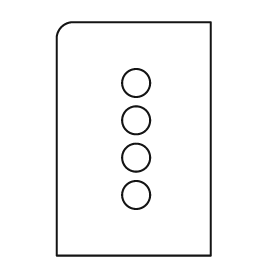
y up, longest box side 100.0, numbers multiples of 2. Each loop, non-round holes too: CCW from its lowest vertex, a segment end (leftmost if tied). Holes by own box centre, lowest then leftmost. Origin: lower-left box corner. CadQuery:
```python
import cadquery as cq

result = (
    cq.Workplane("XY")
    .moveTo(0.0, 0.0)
    .lineTo(66.0, 0.0)
    .lineTo(66.0, 100.0)
    .lineTo(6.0, 100.0)
    .threePointArc((2.0, 98.0), (0.0, 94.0))
    .close()
    .moveTo(34.0, 26.0)
    .circle(6.0)
    .moveTo(34.0, 42.0)
    .circle(6.0)
    .moveTo(34.0, 58.0)
    .circle(6.0)
    .moveTo(34.0, 74.0)
    .circle(6.0)
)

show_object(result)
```